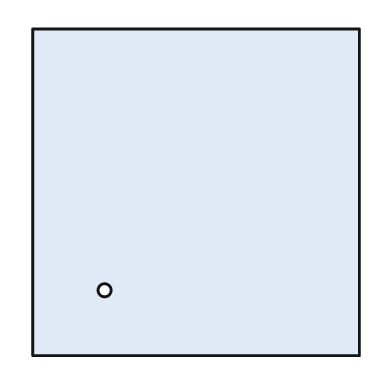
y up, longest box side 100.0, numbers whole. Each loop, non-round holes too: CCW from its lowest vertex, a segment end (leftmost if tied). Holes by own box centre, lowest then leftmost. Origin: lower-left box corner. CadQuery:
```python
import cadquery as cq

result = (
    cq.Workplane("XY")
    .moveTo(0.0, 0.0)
    .lineTo(100.0, 0.0)
    .lineTo(100.0, 100.0)
    .lineTo(0.0, 100.0)
    .close()
    .moveTo(22.0, 20.0)
    .circle(2.0)
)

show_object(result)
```